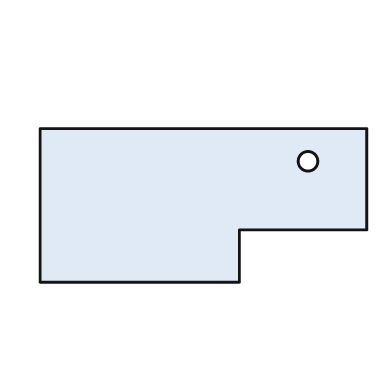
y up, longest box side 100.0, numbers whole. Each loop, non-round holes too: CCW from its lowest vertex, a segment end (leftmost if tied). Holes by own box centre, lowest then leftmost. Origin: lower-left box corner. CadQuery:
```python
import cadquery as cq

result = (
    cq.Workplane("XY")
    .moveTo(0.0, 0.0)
    .lineTo(61.0, 0.0)
    .lineTo(61.0, 16.0)
    .lineTo(100.0, 16.0)
    .lineTo(100.0, 47.0)
    .lineTo(0.0, 47.0)
    .close()
    .moveTo(82.0, 37.0)
    .circle(3.0)
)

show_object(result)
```